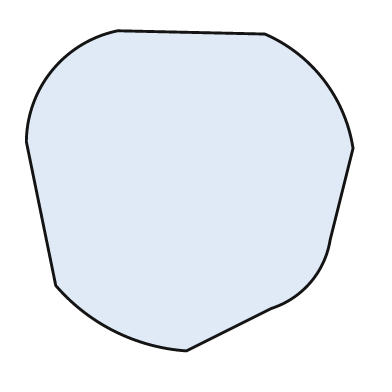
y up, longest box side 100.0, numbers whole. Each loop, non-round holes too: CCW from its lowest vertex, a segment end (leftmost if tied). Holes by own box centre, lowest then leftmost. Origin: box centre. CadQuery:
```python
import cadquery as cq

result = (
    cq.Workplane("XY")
    .moveTo(-1.0, -49.0)
    .lineTo(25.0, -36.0)
    .threePointArc((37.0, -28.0), (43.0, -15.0))
    .lineTo(50.0, 13.0)
    .threePointArc((41.0, 34.0), (23.0, 48.0))
    .lineTo(-22.0, 49.0)
    .threePointArc((-42.0, 37.0), (-50.0, 15.0))
    .lineTo(-41.0, -29.0)
    .threePointArc((-23.0, -43.0), (-1.0, -49.0))
    .close()
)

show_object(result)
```